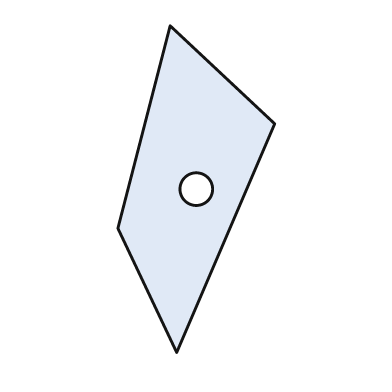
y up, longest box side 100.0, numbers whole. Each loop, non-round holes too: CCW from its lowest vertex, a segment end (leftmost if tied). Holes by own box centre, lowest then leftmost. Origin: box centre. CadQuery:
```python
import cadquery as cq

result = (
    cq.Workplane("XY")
    .moveTo(-6.0, -50.0)
    .lineTo(24.0, 20.0)
    .lineTo(-8.0, 50.0)
    .lineTo(-24.0, -12.0)
    .close()
    .moveTo(0.0, 0.0)
    .circle(5.0)
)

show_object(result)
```